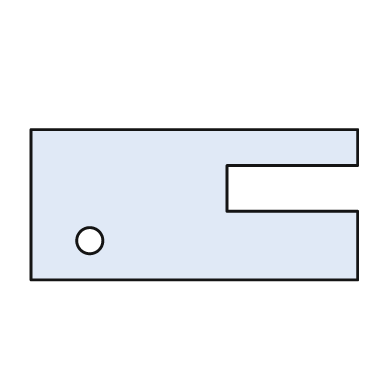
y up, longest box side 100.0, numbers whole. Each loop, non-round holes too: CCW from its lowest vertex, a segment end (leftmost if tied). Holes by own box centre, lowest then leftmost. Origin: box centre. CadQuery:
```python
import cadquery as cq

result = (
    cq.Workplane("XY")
    .moveTo(-50.0, -23.0)
    .lineTo(50.0, -23.0)
    .lineTo(50.0, -2.0)
    .lineTo(10.0, -2.0)
    .lineTo(10.0, 12.0)
    .lineTo(50.0, 12.0)
    .lineTo(50.0, 23.0)
    .lineTo(-50.0, 23.0)
    .close()
    .moveTo(-32.0, -11.0)
    .circle(4.0)
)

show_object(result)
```